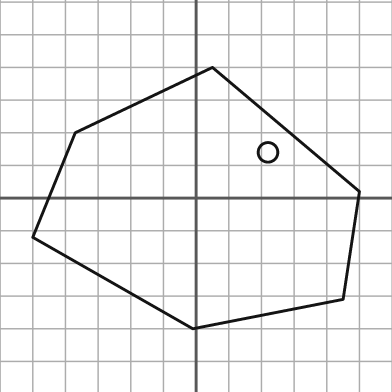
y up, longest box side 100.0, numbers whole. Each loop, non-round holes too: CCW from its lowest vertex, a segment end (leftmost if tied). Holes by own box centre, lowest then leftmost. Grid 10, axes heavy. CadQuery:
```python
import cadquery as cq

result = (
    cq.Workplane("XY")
    .moveTo(-1.0, -40.0)
    .lineTo(45.0, -31.0)
    .lineTo(50.0, 2.0)
    .lineTo(5.0, 40.0)
    .lineTo(-37.0, 20.0)
    .lineTo(-50.0, -12.0)
    .close()
    .moveTo(22.0, 14.0)
    .circle(3.0)
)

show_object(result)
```